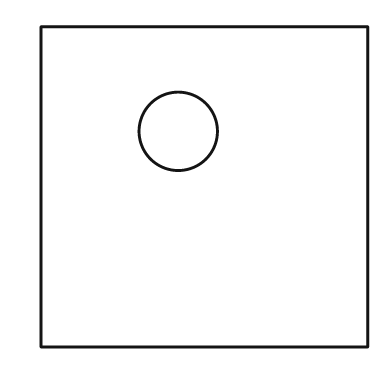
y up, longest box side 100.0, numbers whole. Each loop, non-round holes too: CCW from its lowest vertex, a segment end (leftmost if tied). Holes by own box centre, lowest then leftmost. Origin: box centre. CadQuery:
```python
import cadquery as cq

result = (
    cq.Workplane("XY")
    .moveTo(-50.0, -49.0)
    .lineTo(50.0, -49.0)
    .lineTo(50.0, 49.0)
    .lineTo(-50.0, 49.0)
    .close()
    .moveTo(-8.0, 17.0)
    .circle(12.0)
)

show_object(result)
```